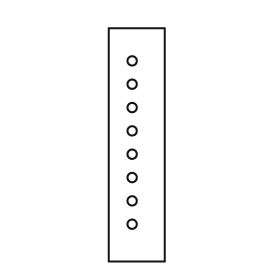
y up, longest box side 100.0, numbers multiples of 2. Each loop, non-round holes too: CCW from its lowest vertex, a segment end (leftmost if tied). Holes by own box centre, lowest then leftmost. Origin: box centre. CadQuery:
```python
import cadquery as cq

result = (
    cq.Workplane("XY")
    .moveTo(-12.0, -50.0)
    .lineTo(12.0, -50.0)
    .lineTo(12.0, 50.0)
    .lineTo(-12.0, 50.0)
    .close()
    .moveTo(-2.0, -34.0)
    .circle(2.0)
    .moveTo(-2.0, -24.0)
    .circle(2.0)
    .moveTo(-2.0, -14.0)
    .circle(2.0)
    .moveTo(-2.0, -4.0)
    .circle(2.0)
    .moveTo(-2.0, 6.0)
    .circle(2.0)
    .moveTo(-2.0, 16.0)
    .circle(2.0)
    .moveTo(-2.0, 26.0)
    .circle(2.0)
    .moveTo(-2.0, 36.0)
    .circle(2.0)
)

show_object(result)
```